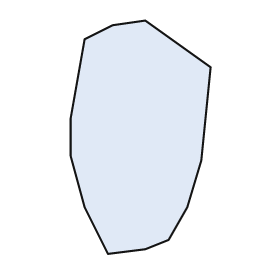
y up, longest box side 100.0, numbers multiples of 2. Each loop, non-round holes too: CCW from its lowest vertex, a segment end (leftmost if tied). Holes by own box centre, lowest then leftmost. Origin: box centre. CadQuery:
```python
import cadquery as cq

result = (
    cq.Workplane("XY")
    .moveTo(-14.0, -50.0)
    .lineTo(2.0, -48.0)
    .lineTo(12.0, -44.0)
    .lineTo(20.0, -30.0)
    .lineTo(26.0, -10.0)
    .lineTo(30.0, 30.0)
    .lineTo(2.0, 50.0)
    .lineTo(-12.0, 48.0)
    .lineTo(-24.0, 42.0)
    .lineTo(-30.0, 8.0)
    .lineTo(-30.0, -8.0)
    .lineTo(-24.0, -30.0)
    .close()
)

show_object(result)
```